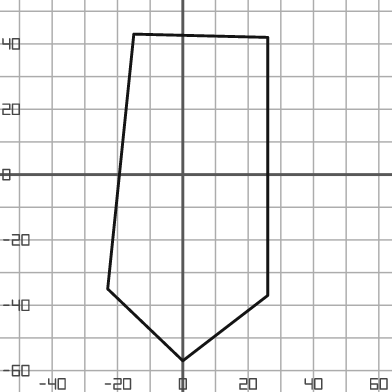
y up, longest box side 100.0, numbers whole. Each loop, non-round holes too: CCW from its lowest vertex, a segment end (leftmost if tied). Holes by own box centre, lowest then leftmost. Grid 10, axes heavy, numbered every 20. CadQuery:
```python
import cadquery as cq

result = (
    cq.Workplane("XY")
    .moveTo(0.0, -57.0)
    .lineTo(26.0, -37.0)
    .lineTo(26.0, 42.0)
    .lineTo(-15.0, 43.0)
    .lineTo(-23.0, -35.0)
    .close()
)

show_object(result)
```